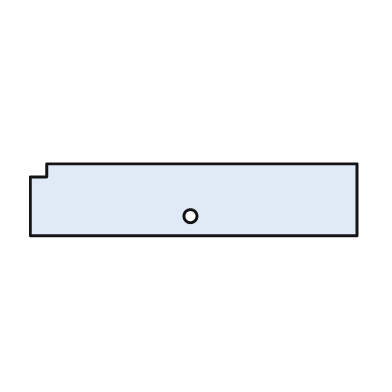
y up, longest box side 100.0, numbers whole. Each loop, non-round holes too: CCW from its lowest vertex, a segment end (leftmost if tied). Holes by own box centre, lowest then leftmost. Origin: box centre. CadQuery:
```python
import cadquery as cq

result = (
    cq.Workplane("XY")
    .moveTo(-50.0, -11.0)
    .lineTo(50.0, -11.0)
    .lineTo(50.0, 11.0)
    .lineTo(-45.0, 11.0)
    .lineTo(-45.0, 7.0)
    .lineTo(-50.0, 7.0)
    .close()
    .moveTo(-1.0, -5.0)
    .circle(2.0)
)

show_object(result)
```